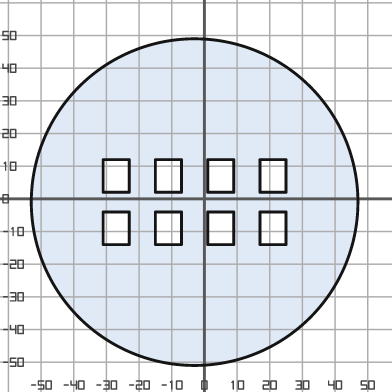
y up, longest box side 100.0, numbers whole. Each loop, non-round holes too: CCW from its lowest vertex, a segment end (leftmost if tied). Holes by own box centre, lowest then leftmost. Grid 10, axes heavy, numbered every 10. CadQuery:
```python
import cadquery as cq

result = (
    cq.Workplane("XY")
    .moveTo(-3.0, -1.0)
    .circle(50.0)
    .moveTo(-31.0, -14.0)
    .lineTo(-23.0, -14.0)
    .lineTo(-23.0, -4.0)
    .lineTo(-31.0, -4.0)
    .close()
    .moveTo(-15.0, -14.0)
    .lineTo(-7.0, -14.0)
    .lineTo(-7.0, -4.0)
    .lineTo(-15.0, -4.0)
    .close()
    .moveTo(1.0, -14.0)
    .lineTo(9.0, -14.0)
    .lineTo(9.0, -4.0)
    .lineTo(1.0, -4.0)
    .close()
    .moveTo(17.0, -14.0)
    .lineTo(25.0, -14.0)
    .lineTo(25.0, -4.0)
    .lineTo(17.0, -4.0)
    .close()
    .moveTo(-31.0, 2.0)
    .lineTo(-23.0, 2.0)
    .lineTo(-23.0, 12.0)
    .lineTo(-31.0, 12.0)
    .close()
    .moveTo(-15.0, 2.0)
    .lineTo(-7.0, 2.0)
    .lineTo(-7.0, 12.0)
    .lineTo(-15.0, 12.0)
    .close()
    .moveTo(1.0, 2.0)
    .lineTo(9.0, 2.0)
    .lineTo(9.0, 12.0)
    .lineTo(1.0, 12.0)
    .close()
    .moveTo(17.0, 2.0)
    .lineTo(25.0, 2.0)
    .lineTo(25.0, 12.0)
    .lineTo(17.0, 12.0)
    .close()
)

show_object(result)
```